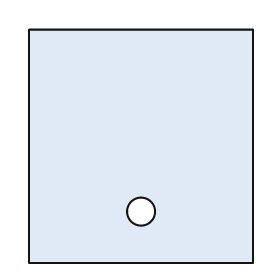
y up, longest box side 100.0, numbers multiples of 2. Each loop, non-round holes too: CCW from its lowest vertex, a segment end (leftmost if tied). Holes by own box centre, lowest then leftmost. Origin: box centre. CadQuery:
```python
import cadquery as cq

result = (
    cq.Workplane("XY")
    .moveTo(-48.0, -50.0)
    .lineTo(48.0, -50.0)
    .lineTo(48.0, 50.0)
    .lineTo(-48.0, 50.0)
    .close()
    .moveTo(0.0, -28.0)
    .circle(6.0)
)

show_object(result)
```